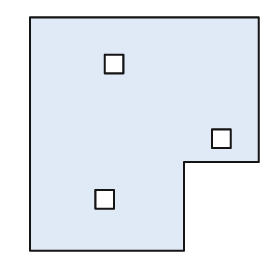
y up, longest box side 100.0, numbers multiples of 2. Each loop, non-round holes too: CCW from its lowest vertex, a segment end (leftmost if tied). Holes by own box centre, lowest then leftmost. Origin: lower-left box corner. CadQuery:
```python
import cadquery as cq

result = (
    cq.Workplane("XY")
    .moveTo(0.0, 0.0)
    .lineTo(66.0, 0.0)
    .lineTo(66.0, 38.0)
    .lineTo(98.0, 38.0)
    .lineTo(98.0, 100.0)
    .lineTo(0.0, 100.0)
    .close()
    .moveTo(28.0, 18.0)
    .lineTo(36.0, 18.0)
    .lineTo(36.0, 26.0)
    .lineTo(28.0, 26.0)
    .close()
    .moveTo(78.0, 44.0)
    .lineTo(86.0, 44.0)
    .lineTo(86.0, 52.0)
    .lineTo(78.0, 52.0)
    .close()
    .moveTo(32.0, 76.0)
    .lineTo(40.0, 76.0)
    .lineTo(40.0, 84.0)
    .lineTo(32.0, 84.0)
    .close()
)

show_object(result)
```